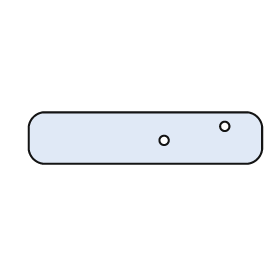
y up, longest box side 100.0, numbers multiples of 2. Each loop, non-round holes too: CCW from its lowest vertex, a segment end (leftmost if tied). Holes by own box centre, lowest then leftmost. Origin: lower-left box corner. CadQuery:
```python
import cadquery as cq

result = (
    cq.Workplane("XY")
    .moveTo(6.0, 0.0)
    .lineTo(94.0, 0.0)
    .threePointArc((98.0, 2.0), (100.0, 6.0))
    .lineTo(100.0, 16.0)
    .threePointArc((98.0, 20.0), (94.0, 22.0))
    .lineTo(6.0, 22.0)
    .threePointArc((2.0, 20.0), (0.0, 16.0))
    .lineTo(0.0, 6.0)
    .threePointArc((2.0, 2.0), (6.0, 0.0))
    .close()
    .moveTo(58.0, 10.0)
    .circle(2.0)
    .moveTo(84.0, 16.0)
    .circle(2.0)
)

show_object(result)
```